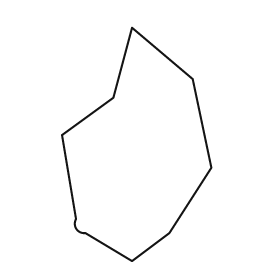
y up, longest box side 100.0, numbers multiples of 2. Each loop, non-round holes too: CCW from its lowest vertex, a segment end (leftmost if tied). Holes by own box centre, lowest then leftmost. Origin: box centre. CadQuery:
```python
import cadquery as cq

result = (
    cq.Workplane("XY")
    .moveTo(-2.0, -50.0)
    .lineTo(14.0, -38.0)
    .lineTo(32.0, -10.0)
    .lineTo(24.0, 28.0)
    .lineTo(-2.0, 50.0)
    .lineTo(-10.0, 20.0)
    .lineTo(-32.0, 4.0)
    .lineTo(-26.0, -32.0)
    .threePointArc((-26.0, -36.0), (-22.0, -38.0))
    .close()
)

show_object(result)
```